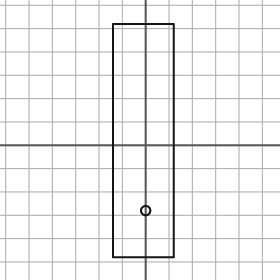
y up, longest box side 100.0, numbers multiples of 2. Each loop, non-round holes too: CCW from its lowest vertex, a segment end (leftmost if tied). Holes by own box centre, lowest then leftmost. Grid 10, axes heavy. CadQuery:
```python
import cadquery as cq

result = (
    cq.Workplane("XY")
    .moveTo(-14.0, -48.0)
    .lineTo(12.0, -48.0)
    .lineTo(12.0, 52.0)
    .lineTo(-14.0, 52.0)
    .close()
    .moveTo(0.0, -28.0)
    .circle(2.0)
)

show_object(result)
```